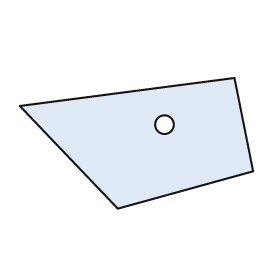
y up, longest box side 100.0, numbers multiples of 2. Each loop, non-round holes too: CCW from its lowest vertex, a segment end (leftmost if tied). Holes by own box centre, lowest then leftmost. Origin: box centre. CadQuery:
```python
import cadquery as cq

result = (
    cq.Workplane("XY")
    .moveTo(-8.0, -28.0)
    .lineTo(50.0, -12.0)
    .lineTo(42.0, 28.0)
    .lineTo(-50.0, 16.0)
    .close()
    .moveTo(12.0, 8.0)
    .circle(4.0)
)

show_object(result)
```